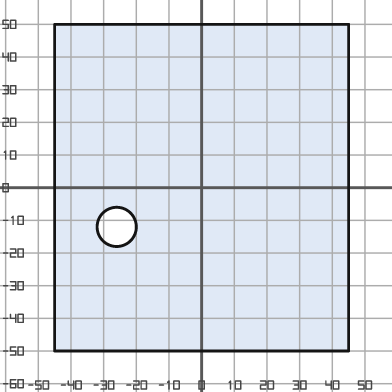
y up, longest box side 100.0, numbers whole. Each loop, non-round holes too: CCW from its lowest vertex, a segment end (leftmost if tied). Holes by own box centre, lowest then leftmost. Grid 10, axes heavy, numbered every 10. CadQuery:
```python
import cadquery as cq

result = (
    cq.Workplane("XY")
    .moveTo(-45.0, -50.0)
    .lineTo(45.0, -50.0)
    .lineTo(45.0, 50.0)
    .lineTo(-45.0, 50.0)
    .close()
    .moveTo(-26.0, -12.0)
    .circle(6.0)
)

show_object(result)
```